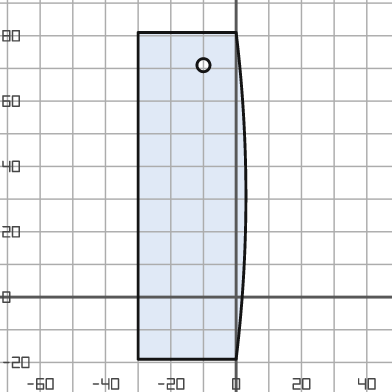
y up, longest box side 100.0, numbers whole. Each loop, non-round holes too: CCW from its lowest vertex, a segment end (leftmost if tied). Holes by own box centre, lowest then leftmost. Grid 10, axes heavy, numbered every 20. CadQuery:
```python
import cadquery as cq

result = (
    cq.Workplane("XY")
    .moveTo(-30.0, -19.0)
    .lineTo(0.0, -19.0)
    .threePointArc((3.0, 31.0), (0.0, 81.0))
    .lineTo(-30.0, 81.0)
    .close()
    .moveTo(-10.0, 71.0)
    .circle(2.0)
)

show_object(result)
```